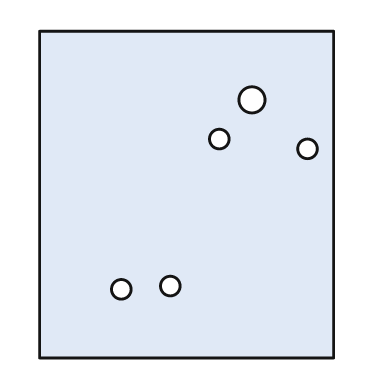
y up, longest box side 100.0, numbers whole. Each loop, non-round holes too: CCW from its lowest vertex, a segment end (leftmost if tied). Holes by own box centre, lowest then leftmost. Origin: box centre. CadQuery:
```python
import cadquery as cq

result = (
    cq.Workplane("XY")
    .moveTo(-45.0, -50.0)
    .lineTo(45.0, -50.0)
    .lineTo(45.0, 50.0)
    .lineTo(-45.0, 50.0)
    .close()
    .moveTo(-20.0, -29.0)
    .circle(3.0)
    .moveTo(-5.0, -28.0)
    .circle(3.0)
    .moveTo(37.0, 14.0)
    .circle(3.0)
    .moveTo(10.0, 17.0)
    .circle(3.0)
    .moveTo(20.0, 29.0)
    .circle(4.0)
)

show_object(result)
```